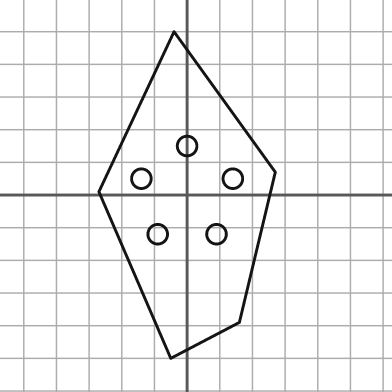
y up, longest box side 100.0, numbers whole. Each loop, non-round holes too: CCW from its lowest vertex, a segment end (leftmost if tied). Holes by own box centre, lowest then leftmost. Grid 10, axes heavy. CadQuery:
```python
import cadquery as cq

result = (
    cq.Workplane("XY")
    .moveTo(-5.0, -50.0)
    .lineTo(16.0, -39.0)
    .lineTo(27.0, 7.0)
    .lineTo(-4.0, 50.0)
    .lineTo(-27.0, 1.0)
    .close()
    .moveTo(-9.0, -12.0)
    .circle(3.0)
    .moveTo(9.0, -12.0)
    .circle(3.0)
    .moveTo(-14.0, 5.0)
    .circle(3.0)
    .moveTo(14.0, 5.0)
    .circle(3.0)
    .moveTo(0.0, 15.0)
    .circle(3.0)
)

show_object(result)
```